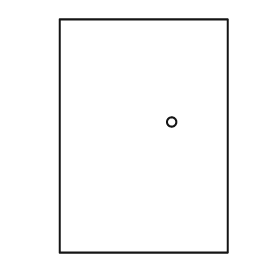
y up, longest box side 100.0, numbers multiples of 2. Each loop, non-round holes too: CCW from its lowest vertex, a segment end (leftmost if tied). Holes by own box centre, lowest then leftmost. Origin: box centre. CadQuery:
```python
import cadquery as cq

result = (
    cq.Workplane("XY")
    .moveTo(-36.0, -50.0)
    .lineTo(36.0, -50.0)
    .lineTo(36.0, 50.0)
    .lineTo(-36.0, 50.0)
    .close()
    .moveTo(12.0, 6.0)
    .circle(2.0)
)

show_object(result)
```